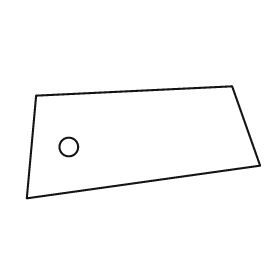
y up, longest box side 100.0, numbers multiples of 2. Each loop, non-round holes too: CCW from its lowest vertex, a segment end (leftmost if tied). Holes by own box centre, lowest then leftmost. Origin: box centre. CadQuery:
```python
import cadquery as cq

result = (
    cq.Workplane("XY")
    .moveTo(-50.0, -24.0)
    .lineTo(50.0, -10.0)
    .lineTo(38.0, 24.0)
    .lineTo(-46.0, 20.0)
    .close()
    .moveTo(-32.0, -2.0)
    .circle(4.0)
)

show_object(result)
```